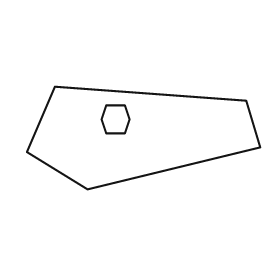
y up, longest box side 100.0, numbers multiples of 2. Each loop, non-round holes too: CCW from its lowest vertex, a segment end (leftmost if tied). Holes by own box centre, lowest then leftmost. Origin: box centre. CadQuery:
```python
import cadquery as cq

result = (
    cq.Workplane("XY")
    .moveTo(-24.0, -22.0)
    .lineTo(50.0, -4.0)
    .lineTo(44.0, 16.0)
    .lineTo(-38.0, 22.0)
    .lineTo(-50.0, -6.0)
    .close()
    .moveTo(-16.0, 2.0)
    .lineTo(-8.0, 2.0)
    .lineTo(-6.0, 8.0)
    .lineTo(-8.0, 14.0)
    .lineTo(-16.0, 14.0)
    .lineTo(-18.0, 8.0)
    .close()
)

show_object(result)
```